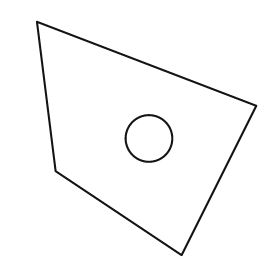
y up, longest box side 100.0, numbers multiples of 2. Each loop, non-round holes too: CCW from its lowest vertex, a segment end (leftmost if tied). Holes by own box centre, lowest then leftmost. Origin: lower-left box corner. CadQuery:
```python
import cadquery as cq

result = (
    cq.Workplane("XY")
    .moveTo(62.0, 0.0)
    .lineTo(94.0, 64.0)
    .lineTo(0.0, 100.0)
    .lineTo(8.0, 36.0)
    .close()
    .moveTo(48.0, 50.0)
    .circle(10.0)
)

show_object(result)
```